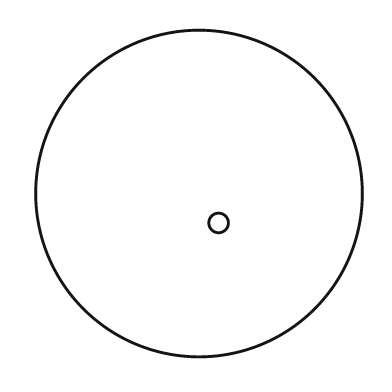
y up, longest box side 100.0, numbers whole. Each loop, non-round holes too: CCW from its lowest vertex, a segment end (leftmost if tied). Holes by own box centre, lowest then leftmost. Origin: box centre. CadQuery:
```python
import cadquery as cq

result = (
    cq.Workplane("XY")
    .moveTo(0.0, 0.0)
    .circle(50.0)
    .moveTo(6.0, -9.0)
    .circle(3.0)
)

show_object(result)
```